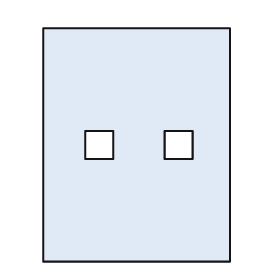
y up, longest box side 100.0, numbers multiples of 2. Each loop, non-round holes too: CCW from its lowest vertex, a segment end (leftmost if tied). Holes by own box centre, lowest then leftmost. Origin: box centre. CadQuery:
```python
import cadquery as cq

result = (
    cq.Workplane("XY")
    .moveTo(-40.0, -50.0)
    .lineTo(40.0, -50.0)
    .lineTo(40.0, 50.0)
    .lineTo(-40.0, 50.0)
    .close()
    .moveTo(-22.0, -6.0)
    .lineTo(-10.0, -6.0)
    .lineTo(-10.0, 6.0)
    .lineTo(-22.0, 6.0)
    .close()
    .moveTo(12.0, -6.0)
    .lineTo(24.0, -6.0)
    .lineTo(24.0, 6.0)
    .lineTo(12.0, 6.0)
    .close()
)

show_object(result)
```